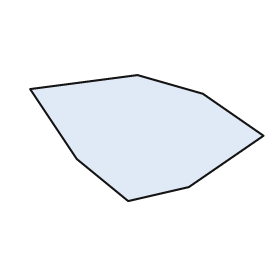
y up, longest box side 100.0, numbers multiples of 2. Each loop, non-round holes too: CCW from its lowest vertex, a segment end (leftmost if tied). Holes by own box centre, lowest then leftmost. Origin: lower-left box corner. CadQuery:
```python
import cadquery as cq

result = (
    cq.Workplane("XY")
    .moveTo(42.0, 0.0)
    .lineTo(68.0, 6.0)
    .lineTo(100.0, 28.0)
    .lineTo(74.0, 46.0)
    .lineTo(46.0, 54.0)
    .lineTo(0.0, 48.0)
    .lineTo(20.0, 18.0)
    .close()
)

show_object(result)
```